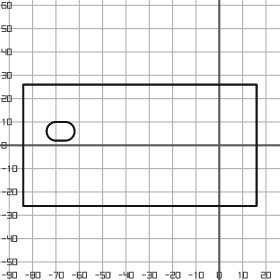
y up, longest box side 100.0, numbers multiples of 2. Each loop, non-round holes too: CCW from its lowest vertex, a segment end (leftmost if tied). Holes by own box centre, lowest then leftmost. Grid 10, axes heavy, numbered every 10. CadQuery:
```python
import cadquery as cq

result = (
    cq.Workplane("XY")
    .moveTo(-84.0, -26.0)
    .lineTo(16.0, -26.0)
    .lineTo(16.0, 26.0)
    .lineTo(-84.0, 26.0)
    .close()
    .moveTo(-70.0, 2.0)
    .lineTo(-66.0, 2.0)
    .threePointArc((-62.0, 6.0), (-66.0, 10.0))
    .lineTo(-70.0, 10.0)
    .threePointArc((-74.0, 6.0), (-70.0, 2.0))
    .close()
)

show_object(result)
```